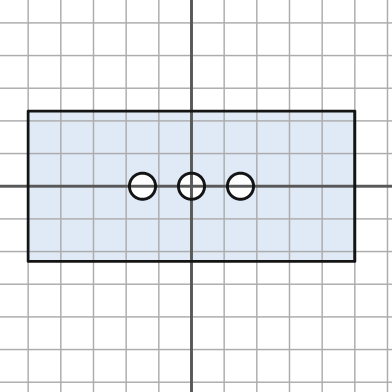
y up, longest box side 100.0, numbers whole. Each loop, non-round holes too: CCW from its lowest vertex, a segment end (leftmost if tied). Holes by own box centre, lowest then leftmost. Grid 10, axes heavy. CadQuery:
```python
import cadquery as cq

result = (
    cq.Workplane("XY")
    .moveTo(-50.0, -23.0)
    .lineTo(50.0, -23.0)
    .lineTo(50.0, 23.0)
    .lineTo(-50.0, 23.0)
    .close()
    .moveTo(-15.0, 0.0)
    .circle(4.0)
    .moveTo(0.0, 0.0)
    .circle(4.0)
    .moveTo(15.0, 0.0)
    .circle(4.0)
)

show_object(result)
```